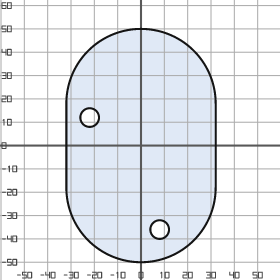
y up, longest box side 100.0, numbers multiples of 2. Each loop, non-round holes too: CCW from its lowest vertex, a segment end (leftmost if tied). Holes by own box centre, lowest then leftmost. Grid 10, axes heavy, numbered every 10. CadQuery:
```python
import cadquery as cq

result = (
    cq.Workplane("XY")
    .moveTo(-32.0, -18.0)
    .threePointArc((0.0, -50.0), (32.0, -18.0))
    .lineTo(32.0, 18.0)
    .threePointArc((0.0, 50.0), (-32.0, 18.0))
    .close()
    .moveTo(8.0, -36.0)
    .circle(4.0)
    .moveTo(-22.0, 12.0)
    .circle(4.0)
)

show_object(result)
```